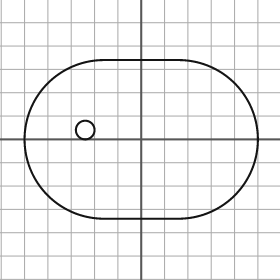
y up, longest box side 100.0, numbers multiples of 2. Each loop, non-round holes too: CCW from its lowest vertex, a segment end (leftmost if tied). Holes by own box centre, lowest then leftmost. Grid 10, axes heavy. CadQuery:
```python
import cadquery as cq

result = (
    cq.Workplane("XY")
    .moveTo(-16.0, -34.0)
    .lineTo(16.0, -34.0)
    .threePointArc((50.0, 0.0), (16.0, 34.0))
    .lineTo(-16.0, 34.0)
    .threePointArc((-50.0, 0.0), (-16.0, -34.0))
    .close()
    .moveTo(-24.0, 4.0)
    .circle(4.0)
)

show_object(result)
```